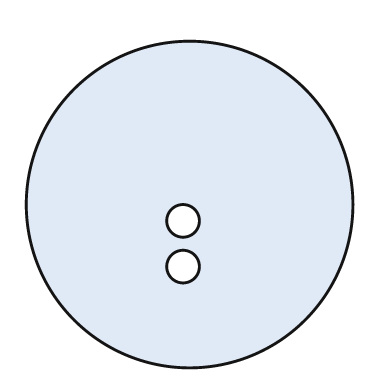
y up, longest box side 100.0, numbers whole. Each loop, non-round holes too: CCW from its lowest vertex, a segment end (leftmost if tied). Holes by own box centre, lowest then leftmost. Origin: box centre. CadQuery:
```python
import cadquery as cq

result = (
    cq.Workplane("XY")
    .moveTo(0.0, 0.0)
    .circle(50.0)
    .moveTo(-2.0, -19.0)
    .circle(5.0)
    .moveTo(-2.0, -5.0)
    .circle(5.0)
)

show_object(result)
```